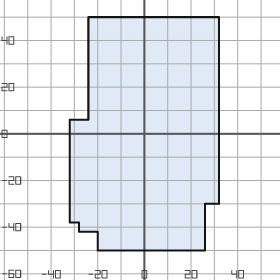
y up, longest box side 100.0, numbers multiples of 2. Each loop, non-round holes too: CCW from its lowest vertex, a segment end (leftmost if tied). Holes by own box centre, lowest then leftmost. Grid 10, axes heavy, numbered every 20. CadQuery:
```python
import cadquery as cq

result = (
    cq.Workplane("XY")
    .moveTo(-20.0, -50.0)
    .lineTo(26.0, -50.0)
    .lineTo(26.0, -30.0)
    .lineTo(32.0, -30.0)
    .lineTo(32.0, 50.0)
    .lineTo(-24.0, 50.0)
    .lineTo(-24.0, 6.0)
    .lineTo(-32.0, 6.0)
    .lineTo(-32.0, -38.0)
    .lineTo(-28.0, -38.0)
    .lineTo(-28.0, -42.0)
    .lineTo(-20.0, -42.0)
    .close()
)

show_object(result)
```